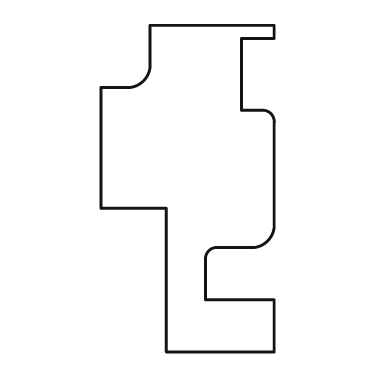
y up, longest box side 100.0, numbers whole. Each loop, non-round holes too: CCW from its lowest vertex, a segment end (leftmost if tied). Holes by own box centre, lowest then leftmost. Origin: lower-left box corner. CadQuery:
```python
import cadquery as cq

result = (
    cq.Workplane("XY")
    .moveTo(20.0, 0.0)
    .lineTo(53.0, 0.0)
    .lineTo(53.0, 16.0)
    .lineTo(32.0, 16.0)
    .lineTo(32.0, 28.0)
    .threePointArc((33.0, 31.0), (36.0, 32.0))
    .lineTo(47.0, 32.0)
    .threePointArc((51.0, 34.0), (53.0, 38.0))
    .lineTo(53.0, 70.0)
    .threePointArc((52.0, 73.0), (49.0, 74.0))
    .lineTo(43.0, 74.0)
    .lineTo(43.0, 96.0)
    .lineTo(53.0, 96.0)
    .lineTo(53.0, 100.0)
    .lineTo(15.0, 100.0)
    .lineTo(15.0, 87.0)
    .threePointArc((13.0, 83.0), (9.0, 81.0))
    .lineTo(0.0, 81.0)
    .lineTo(0.0, 44.0)
    .lineTo(20.0, 44.0)
    .close()
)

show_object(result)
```